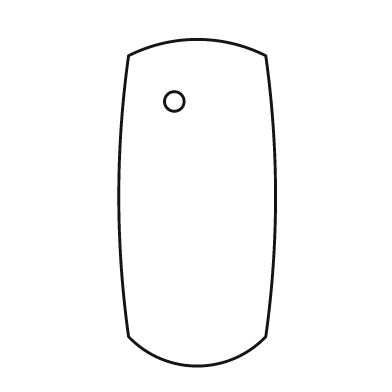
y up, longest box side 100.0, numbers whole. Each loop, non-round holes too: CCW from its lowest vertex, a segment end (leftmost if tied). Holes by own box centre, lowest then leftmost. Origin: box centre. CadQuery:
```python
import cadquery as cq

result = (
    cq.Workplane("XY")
    .moveTo(-21.0, -41.0)
    .threePointArc((0.0, -50.0), (21.0, -41.0))
    .threePointArc((24.0, 2.0), (21.0, 45.0))
    .threePointArc((0.0, 50.0), (-21.0, 45.0))
    .threePointArc((-24.0, 2.0), (-21.0, -41.0))
    .close()
    .moveTo(-7.0, 31.0)
    .circle(3.0)
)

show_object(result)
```